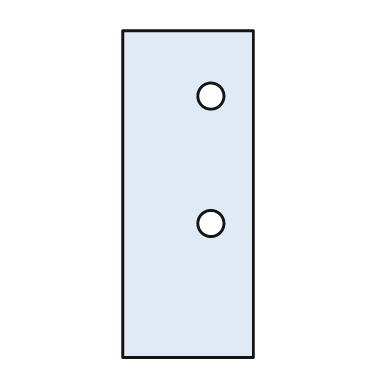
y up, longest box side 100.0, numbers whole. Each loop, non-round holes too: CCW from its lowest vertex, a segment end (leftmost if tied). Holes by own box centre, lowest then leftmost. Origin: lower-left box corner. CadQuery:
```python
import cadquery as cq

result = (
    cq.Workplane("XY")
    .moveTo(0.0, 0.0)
    .lineTo(40.0, 0.0)
    .lineTo(40.0, 100.0)
    .lineTo(0.0, 100.0)
    .close()
    .moveTo(27.0, 41.0)
    .circle(4.0)
    .moveTo(27.0, 80.0)
    .circle(4.0)
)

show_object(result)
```